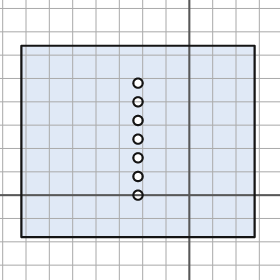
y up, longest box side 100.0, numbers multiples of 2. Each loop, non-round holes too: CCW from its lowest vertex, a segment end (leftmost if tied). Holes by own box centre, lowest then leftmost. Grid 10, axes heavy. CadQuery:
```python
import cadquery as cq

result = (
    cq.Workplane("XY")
    .moveTo(-72.0, -18.0)
    .lineTo(28.0, -18.0)
    .lineTo(28.0, 64.0)
    .lineTo(-72.0, 64.0)
    .close()
    .moveTo(-22.0, 0.0)
    .circle(2.0)
    .moveTo(-22.0, 8.0)
    .circle(2.0)
    .moveTo(-22.0, 16.0)
    .circle(2.0)
    .moveTo(-22.0, 24.0)
    .circle(2.0)
    .moveTo(-22.0, 32.0)
    .circle(2.0)
    .moveTo(-22.0, 40.0)
    .circle(2.0)
    .moveTo(-22.0, 48.0)
    .circle(2.0)
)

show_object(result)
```